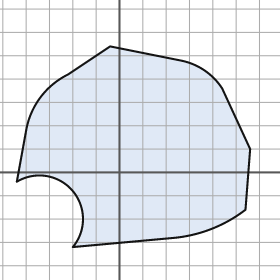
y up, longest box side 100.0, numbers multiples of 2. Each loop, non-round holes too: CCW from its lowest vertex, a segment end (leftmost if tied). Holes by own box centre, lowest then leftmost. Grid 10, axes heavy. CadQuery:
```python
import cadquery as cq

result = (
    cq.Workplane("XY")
    .moveTo(-20.0, -32.0)
    .lineTo(24.0, -28.0)
    .threePointArc((40.0, -24.0), (54.0, -16.0))
    .lineTo(56.0, 10.0)
    .lineTo(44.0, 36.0)
    .threePointArc((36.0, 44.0), (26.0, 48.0))
    .lineTo(-4.0, 54.0)
    .lineTo(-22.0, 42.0)
    .threePointArc((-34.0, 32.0), (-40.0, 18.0))
    .lineTo(-44.0, -4.0)
    .threePointArc((-20.0, -8.0), (-20.0, -32.0))
    .close()
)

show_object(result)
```